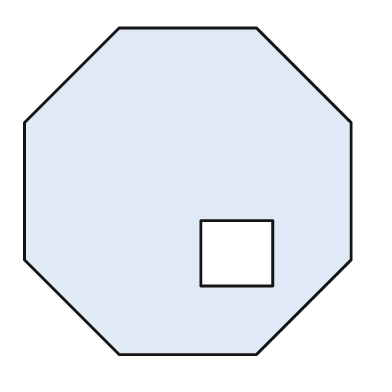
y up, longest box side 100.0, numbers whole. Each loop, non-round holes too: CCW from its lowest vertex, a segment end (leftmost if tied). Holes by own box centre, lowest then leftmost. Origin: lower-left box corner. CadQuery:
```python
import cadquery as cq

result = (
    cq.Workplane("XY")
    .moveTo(29.0, 0.0)
    .lineTo(71.0, 0.0)
    .lineTo(100.0, 29.0)
    .lineTo(100.0, 71.0)
    .lineTo(71.0, 100.0)
    .lineTo(29.0, 100.0)
    .lineTo(0.0, 71.0)
    .lineTo(0.0, 29.0)
    .close()
    .moveTo(54.0, 21.0)
    .lineTo(76.0, 21.0)
    .lineTo(76.0, 41.0)
    .lineTo(54.0, 41.0)
    .close()
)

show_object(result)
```